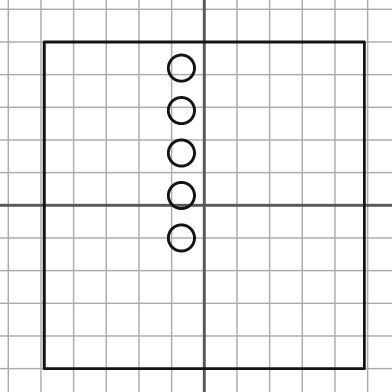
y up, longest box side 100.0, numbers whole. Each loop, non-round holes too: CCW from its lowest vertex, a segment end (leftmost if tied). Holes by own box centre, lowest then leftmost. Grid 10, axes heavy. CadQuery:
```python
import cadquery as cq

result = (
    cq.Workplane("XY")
    .moveTo(-49.0, -50.0)
    .lineTo(49.0, -50.0)
    .lineTo(49.0, 50.0)
    .lineTo(-49.0, 50.0)
    .close()
    .moveTo(-7.0, -10.0)
    .circle(4.0)
    .moveTo(-7.0, 3.0)
    .circle(4.0)
    .moveTo(-7.0, 16.0)
    .circle(4.0)
    .moveTo(-7.0, 29.0)
    .circle(4.0)
    .moveTo(-7.0, 42.0)
    .circle(4.0)
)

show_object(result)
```